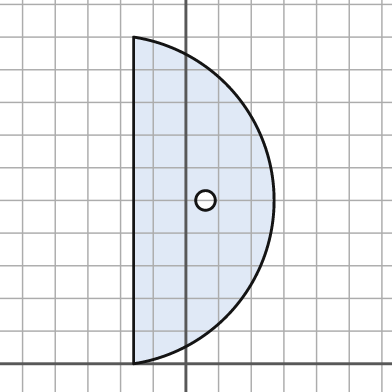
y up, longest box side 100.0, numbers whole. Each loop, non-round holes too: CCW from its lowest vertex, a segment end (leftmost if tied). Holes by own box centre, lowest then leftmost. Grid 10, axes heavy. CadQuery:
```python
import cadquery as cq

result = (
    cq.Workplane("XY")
    .moveTo(-16.0, 0.0)
    .threePointArc((27.0, 50.0), (-16.0, 100.0))
    .close()
    .moveTo(6.0, 50.0)
    .circle(3.0)
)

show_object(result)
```